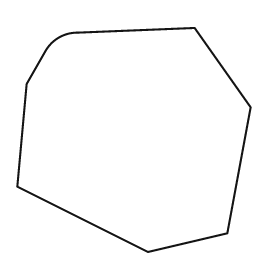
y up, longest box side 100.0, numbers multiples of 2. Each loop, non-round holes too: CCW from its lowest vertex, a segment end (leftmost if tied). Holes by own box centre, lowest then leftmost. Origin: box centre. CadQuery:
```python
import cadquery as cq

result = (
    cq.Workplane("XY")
    .moveTo(6.0, -48.0)
    .lineTo(40.0, -40.0)
    .lineTo(50.0, 14.0)
    .lineTo(26.0, 48.0)
    .lineTo(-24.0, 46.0)
    .threePointArc((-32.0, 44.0), (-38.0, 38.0))
    .lineTo(-46.0, 24.0)
    .lineTo(-50.0, -20.0)
    .close()
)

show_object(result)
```